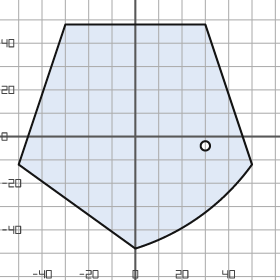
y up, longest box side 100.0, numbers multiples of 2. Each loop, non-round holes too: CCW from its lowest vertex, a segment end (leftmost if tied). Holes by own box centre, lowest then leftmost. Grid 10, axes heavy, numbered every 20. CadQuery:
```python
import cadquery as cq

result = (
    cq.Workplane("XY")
    .moveTo(0.0, -48.0)
    .threePointArc((28.0, -34.0), (50.0, -12.0))
    .lineTo(30.0, 48.0)
    .lineTo(-30.0, 48.0)
    .lineTo(-50.0, -12.0)
    .close()
    .moveTo(30.0, -4.0)
    .circle(2.0)
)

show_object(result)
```